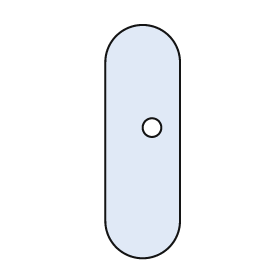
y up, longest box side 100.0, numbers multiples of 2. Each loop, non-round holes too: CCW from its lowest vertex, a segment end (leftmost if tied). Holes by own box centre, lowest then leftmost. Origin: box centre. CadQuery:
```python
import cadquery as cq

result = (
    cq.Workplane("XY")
    .moveTo(-16.0, -34.0)
    .threePointArc((0.0, -50.0), (16.0, -34.0))
    .lineTo(16.0, 34.0)
    .threePointArc((0.0, 50.0), (-16.0, 34.0))
    .close()
    .moveTo(4.0, 6.0)
    .circle(4.0)
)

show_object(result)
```